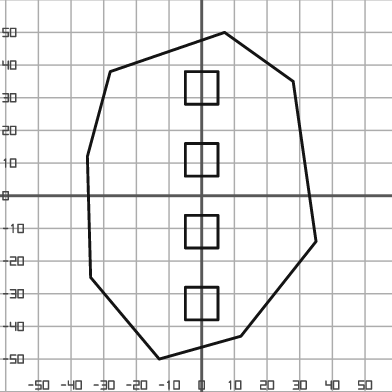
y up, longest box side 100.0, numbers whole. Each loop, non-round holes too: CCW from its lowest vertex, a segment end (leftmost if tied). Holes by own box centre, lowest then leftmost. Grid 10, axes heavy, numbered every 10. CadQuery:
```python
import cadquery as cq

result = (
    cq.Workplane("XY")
    .moveTo(-13.0, -50.0)
    .lineTo(12.0, -43.0)
    .lineTo(35.0, -14.0)
    .lineTo(28.0, 35.0)
    .lineTo(7.0, 50.0)
    .lineTo(-28.0, 38.0)
    .lineTo(-35.0, 12.0)
    .lineTo(-34.0, -25.0)
    .close()
    .moveTo(-5.0, -38.0)
    .lineTo(5.0, -38.0)
    .lineTo(5.0, -28.0)
    .lineTo(-5.0, -28.0)
    .close()
    .moveTo(-5.0, -16.0)
    .lineTo(5.0, -16.0)
    .lineTo(5.0, -6.0)
    .lineTo(-5.0, -6.0)
    .close()
    .moveTo(-5.0, 6.0)
    .lineTo(5.0, 6.0)
    .lineTo(5.0, 16.0)
    .lineTo(-5.0, 16.0)
    .close()
    .moveTo(-5.0, 28.0)
    .lineTo(5.0, 28.0)
    .lineTo(5.0, 38.0)
    .lineTo(-5.0, 38.0)
    .close()
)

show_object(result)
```